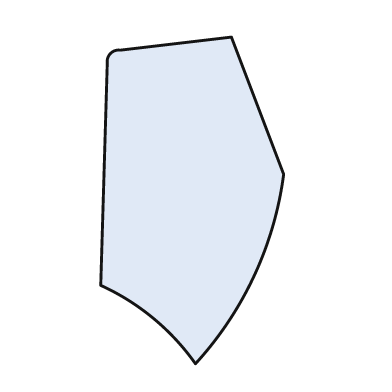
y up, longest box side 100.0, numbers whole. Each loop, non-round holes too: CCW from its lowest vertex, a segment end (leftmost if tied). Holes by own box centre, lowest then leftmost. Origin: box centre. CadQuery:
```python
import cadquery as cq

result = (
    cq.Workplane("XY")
    .moveTo(1.0, -50.0)
    .threePointArc((19.0, -23.0), (28.0, 8.0))
    .lineTo(12.0, 50.0)
    .lineTo(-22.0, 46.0)
    .threePointArc((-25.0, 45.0), (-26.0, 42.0))
    .lineTo(-28.0, -26.0)
    .threePointArc((-12.0, -36.0), (1.0, -50.0))
    .close()
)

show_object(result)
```